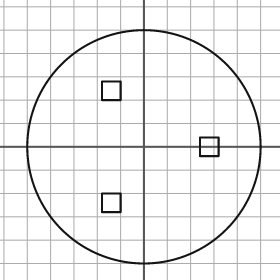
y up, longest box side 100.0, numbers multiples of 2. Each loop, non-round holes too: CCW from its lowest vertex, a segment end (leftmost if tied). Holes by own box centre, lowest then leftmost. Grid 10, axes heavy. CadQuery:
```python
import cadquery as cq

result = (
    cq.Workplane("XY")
    .moveTo(0.0, 0.0)
    .circle(50.0)
    .moveTo(-18.0, -28.0)
    .lineTo(-10.0, -28.0)
    .lineTo(-10.0, -20.0)
    .lineTo(-18.0, -20.0)
    .close()
    .moveTo(24.0, -4.0)
    .lineTo(32.0, -4.0)
    .lineTo(32.0, 4.0)
    .lineTo(24.0, 4.0)
    .close()
    .moveTo(-18.0, 20.0)
    .lineTo(-10.0, 20.0)
    .lineTo(-10.0, 28.0)
    .lineTo(-18.0, 28.0)
    .close()
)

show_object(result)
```